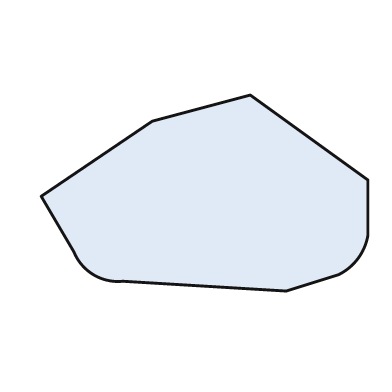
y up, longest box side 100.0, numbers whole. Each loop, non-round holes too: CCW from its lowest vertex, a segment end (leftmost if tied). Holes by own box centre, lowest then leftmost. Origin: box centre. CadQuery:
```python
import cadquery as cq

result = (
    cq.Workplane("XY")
    .moveTo(25.0, -30.0)
    .lineTo(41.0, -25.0)
    .threePointArc((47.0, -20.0), (50.0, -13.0))
    .lineTo(50.0, 4.0)
    .lineTo(14.0, 30.0)
    .lineTo(-16.0, 22.0)
    .lineTo(-50.0, -1.0)
    .lineTo(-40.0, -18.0)
    .threePointArc((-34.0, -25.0), (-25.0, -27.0))
    .close()
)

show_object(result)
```